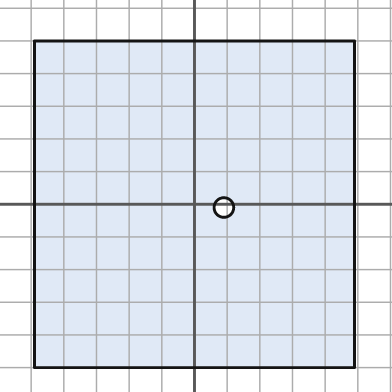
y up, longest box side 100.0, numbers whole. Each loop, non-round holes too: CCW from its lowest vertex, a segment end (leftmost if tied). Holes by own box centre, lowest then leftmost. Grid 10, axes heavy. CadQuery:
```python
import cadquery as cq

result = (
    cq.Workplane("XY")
    .moveTo(-49.0, -50.0)
    .lineTo(49.0, -50.0)
    .lineTo(49.0, 50.0)
    .lineTo(-49.0, 50.0)
    .close()
    .moveTo(9.0, -1.0)
    .circle(3.0)
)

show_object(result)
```